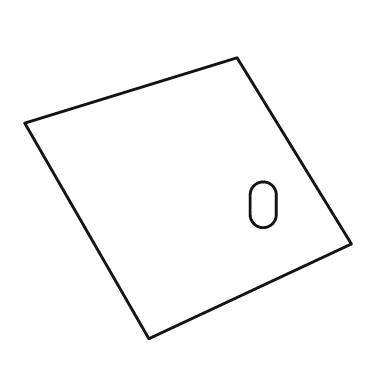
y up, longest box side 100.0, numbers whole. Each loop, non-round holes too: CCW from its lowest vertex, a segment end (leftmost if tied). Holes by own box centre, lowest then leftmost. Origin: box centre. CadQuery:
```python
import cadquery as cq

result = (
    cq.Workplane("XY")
    .moveTo(-12.0, -43.0)
    .lineTo(50.0, -14.0)
    .lineTo(15.0, 43.0)
    .lineTo(-50.0, 23.0)
    .close()
    .moveTo(19.0, -5.0)
    .threePointArc((23.0, -9.0), (27.0, -5.0))
    .lineTo(27.0, 1.0)
    .threePointArc((23.0, 5.0), (19.0, 1.0))
    .close()
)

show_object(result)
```